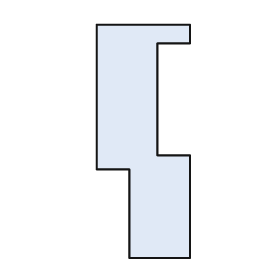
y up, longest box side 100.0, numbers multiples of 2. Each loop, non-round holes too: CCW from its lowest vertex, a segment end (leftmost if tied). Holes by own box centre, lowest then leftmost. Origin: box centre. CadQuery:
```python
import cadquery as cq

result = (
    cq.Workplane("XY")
    .moveTo(-6.0, -50.0)
    .lineTo(20.0, -50.0)
    .lineTo(20.0, -6.0)
    .lineTo(6.0, -6.0)
    .lineTo(6.0, 42.0)
    .lineTo(20.0, 42.0)
    .lineTo(20.0, 50.0)
    .lineTo(-20.0, 50.0)
    .lineTo(-20.0, -12.0)
    .lineTo(-6.0, -12.0)
    .close()
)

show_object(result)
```